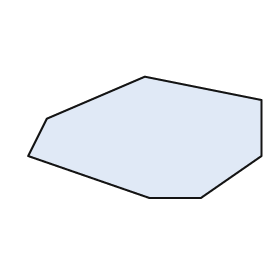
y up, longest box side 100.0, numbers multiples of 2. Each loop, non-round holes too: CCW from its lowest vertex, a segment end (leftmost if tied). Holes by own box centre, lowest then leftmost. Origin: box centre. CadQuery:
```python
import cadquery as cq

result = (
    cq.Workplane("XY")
    .moveTo(2.0, -26.0)
    .lineTo(24.0, -26.0)
    .lineTo(50.0, -8.0)
    .lineTo(50.0, 16.0)
    .lineTo(0.0, 26.0)
    .lineTo(-42.0, 8.0)
    .lineTo(-50.0, -8.0)
    .close()
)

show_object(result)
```